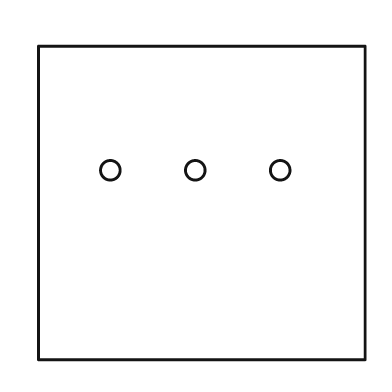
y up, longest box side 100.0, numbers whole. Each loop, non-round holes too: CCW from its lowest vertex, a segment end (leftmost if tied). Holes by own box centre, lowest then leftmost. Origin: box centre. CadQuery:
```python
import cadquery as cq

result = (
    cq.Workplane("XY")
    .moveTo(-50.0, -48.0)
    .lineTo(50.0, -48.0)
    .lineTo(50.0, 48.0)
    .lineTo(-50.0, 48.0)
    .close()
    .moveTo(-28.0, 10.0)
    .circle(3.0)
    .moveTo(-2.0, 10.0)
    .circle(3.0)
    .moveTo(24.0, 10.0)
    .circle(3.0)
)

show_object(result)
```